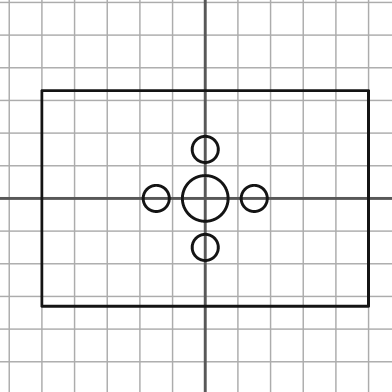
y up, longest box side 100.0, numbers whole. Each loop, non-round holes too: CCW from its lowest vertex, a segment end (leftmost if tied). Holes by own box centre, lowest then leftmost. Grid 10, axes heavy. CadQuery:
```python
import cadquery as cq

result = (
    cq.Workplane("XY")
    .moveTo(-50.0, -33.0)
    .lineTo(50.0, -33.0)
    .lineTo(50.0, 33.0)
    .lineTo(-50.0, 33.0)
    .close()
    .moveTo(0.0, -15.0)
    .circle(4.0)
    .moveTo(-15.0, 0.0)
    .circle(4.0)
    .moveTo(0.0, 0.0)
    .circle(7.0)
    .moveTo(15.0, 0.0)
    .circle(4.0)
    .moveTo(0.0, 15.0)
    .circle(4.0)
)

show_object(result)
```